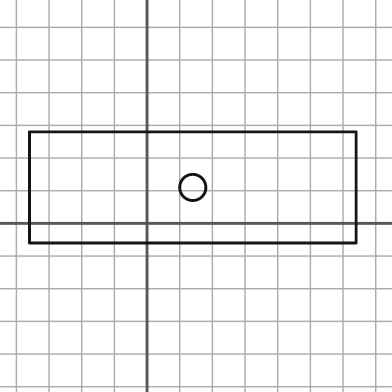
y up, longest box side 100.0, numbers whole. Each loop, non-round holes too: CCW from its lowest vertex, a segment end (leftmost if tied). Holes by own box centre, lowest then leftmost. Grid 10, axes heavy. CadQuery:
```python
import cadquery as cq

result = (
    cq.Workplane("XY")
    .moveTo(-36.0, -6.0)
    .lineTo(64.0, -6.0)
    .lineTo(64.0, 28.0)
    .lineTo(-36.0, 28.0)
    .close()
    .moveTo(14.0, 11.0)
    .circle(4.0)
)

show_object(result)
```